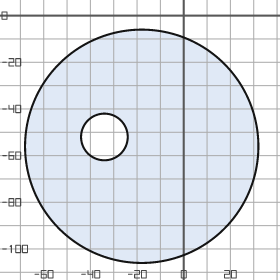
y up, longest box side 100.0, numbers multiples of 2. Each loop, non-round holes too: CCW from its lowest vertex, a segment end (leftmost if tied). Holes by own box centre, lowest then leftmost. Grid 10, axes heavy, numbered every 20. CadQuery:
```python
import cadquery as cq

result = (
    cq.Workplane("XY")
    .moveTo(-18.0, -56.0)
    .circle(50.0)
    .moveTo(-34.0, -52.0)
    .circle(10.0)
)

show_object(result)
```